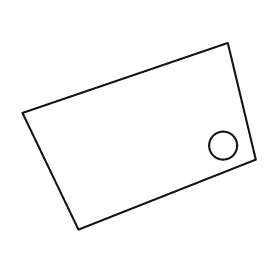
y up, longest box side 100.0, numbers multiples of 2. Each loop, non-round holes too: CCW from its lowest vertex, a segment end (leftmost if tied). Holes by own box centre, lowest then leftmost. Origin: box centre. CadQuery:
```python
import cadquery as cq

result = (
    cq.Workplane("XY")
    .moveTo(-26.0, -40.0)
    .lineTo(50.0, -10.0)
    .lineTo(38.0, 40.0)
    .lineTo(-50.0, 10.0)
    .close()
    .moveTo(36.0, -4.0)
    .circle(6.0)
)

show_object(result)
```